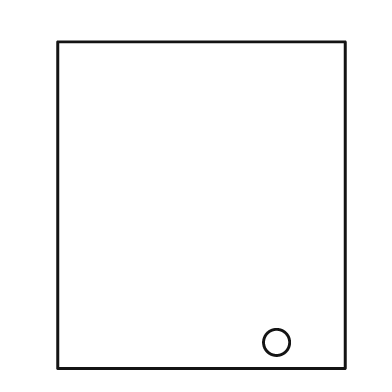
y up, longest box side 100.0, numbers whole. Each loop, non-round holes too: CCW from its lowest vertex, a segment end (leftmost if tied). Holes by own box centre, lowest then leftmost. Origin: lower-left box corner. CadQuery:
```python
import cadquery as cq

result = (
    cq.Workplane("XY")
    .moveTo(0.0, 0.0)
    .lineTo(88.0, 0.0)
    .lineTo(88.0, 100.0)
    .lineTo(0.0, 100.0)
    .close()
    .moveTo(67.0, 8.0)
    .circle(4.0)
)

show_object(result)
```